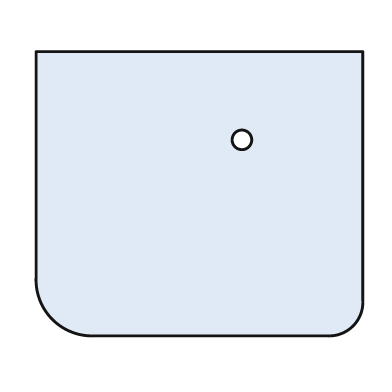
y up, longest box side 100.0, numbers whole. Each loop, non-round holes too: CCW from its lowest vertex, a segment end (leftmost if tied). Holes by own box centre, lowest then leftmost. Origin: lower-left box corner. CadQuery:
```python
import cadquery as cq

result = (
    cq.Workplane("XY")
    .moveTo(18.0, 0.0)
    .lineTo(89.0, 0.0)
    .threePointArc((97.0, 3.0), (100.0, 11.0))
    .lineTo(100.0, 87.0)
    .lineTo(0.0, 87.0)
    .lineTo(0.0, 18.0)
    .threePointArc((5.0, 5.0), (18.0, 0.0))
    .close()
    .moveTo(63.0, 60.0)
    .circle(3.0)
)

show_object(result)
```